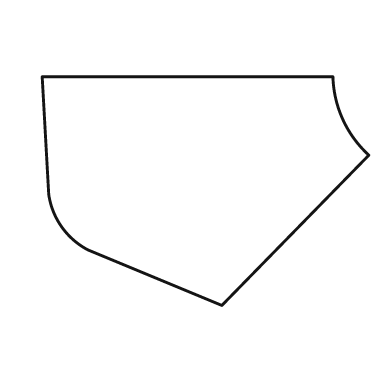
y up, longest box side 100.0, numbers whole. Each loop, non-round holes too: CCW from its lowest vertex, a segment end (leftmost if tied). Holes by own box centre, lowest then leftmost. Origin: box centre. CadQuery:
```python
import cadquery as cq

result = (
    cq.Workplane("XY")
    .moveTo(5.0, -35.0)
    .lineTo(50.0, 11.0)
    .threePointArc((42.0, 22.0), (39.0, 35.0))
    .lineTo(-50.0, 35.0)
    .lineTo(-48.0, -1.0)
    .threePointArc((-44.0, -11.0), (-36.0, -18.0))
    .close()
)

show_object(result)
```